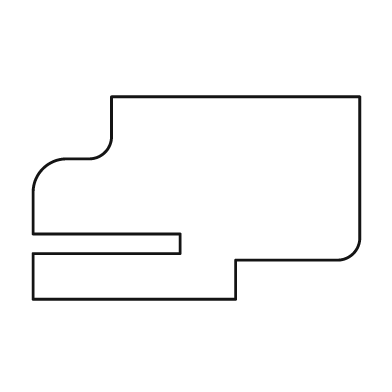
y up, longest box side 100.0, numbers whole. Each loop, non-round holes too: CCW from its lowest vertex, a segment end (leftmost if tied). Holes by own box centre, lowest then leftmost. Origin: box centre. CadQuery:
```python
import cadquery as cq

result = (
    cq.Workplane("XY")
    .moveTo(-50.0, -31.0)
    .lineTo(12.0, -31.0)
    .lineTo(12.0, -19.0)
    .lineTo(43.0, -19.0)
    .threePointArc((48.0, -17.0), (50.0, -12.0))
    .lineTo(50.0, 31.0)
    .lineTo(-26.0, 31.0)
    .lineTo(-26.0, 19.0)
    .threePointArc((-28.0, 14.0), (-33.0, 12.0))
    .lineTo(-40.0, 12.0)
    .threePointArc((-47.0, 9.0), (-50.0, 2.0))
    .lineTo(-50.0, -11.0)
    .lineTo(-5.0, -11.0)
    .lineTo(-5.0, -17.0)
    .lineTo(-50.0, -17.0)
    .close()
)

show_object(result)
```